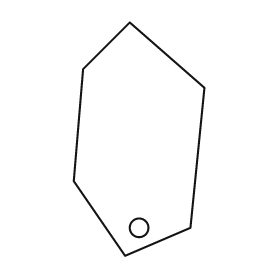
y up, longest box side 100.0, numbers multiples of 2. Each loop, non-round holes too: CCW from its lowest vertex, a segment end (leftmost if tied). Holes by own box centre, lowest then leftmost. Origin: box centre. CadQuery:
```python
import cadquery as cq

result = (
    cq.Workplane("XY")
    .moveTo(-6.0, -50.0)
    .lineTo(22.0, -38.0)
    .lineTo(28.0, 22.0)
    .lineTo(-4.0, 50.0)
    .lineTo(-24.0, 30.0)
    .lineTo(-28.0, -18.0)
    .close()
    .moveTo(0.0, -38.0)
    .circle(4.0)
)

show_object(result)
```